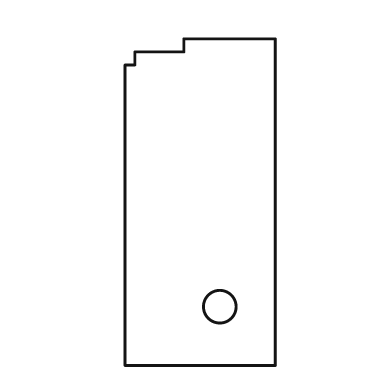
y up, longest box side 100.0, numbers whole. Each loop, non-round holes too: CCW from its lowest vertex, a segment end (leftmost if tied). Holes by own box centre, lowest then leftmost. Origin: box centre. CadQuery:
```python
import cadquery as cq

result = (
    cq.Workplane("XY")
    .moveTo(-23.0, -50.0)
    .lineTo(23.0, -50.0)
    .lineTo(23.0, 50.0)
    .lineTo(-5.0, 50.0)
    .lineTo(-5.0, 46.0)
    .lineTo(-20.0, 46.0)
    .lineTo(-20.0, 42.0)
    .lineTo(-23.0, 42.0)
    .close()
    .moveTo(6.0, -32.0)
    .circle(5.0)
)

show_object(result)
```